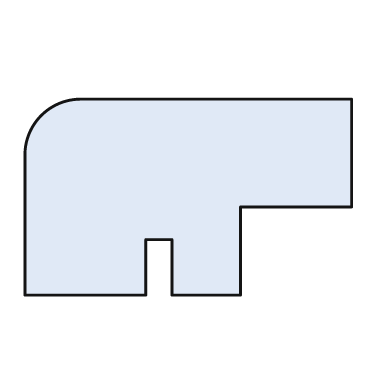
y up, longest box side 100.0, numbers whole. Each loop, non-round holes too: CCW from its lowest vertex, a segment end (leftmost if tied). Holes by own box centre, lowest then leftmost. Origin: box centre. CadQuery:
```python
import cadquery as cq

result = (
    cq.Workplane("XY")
    .moveTo(-50.0, -30.0)
    .lineTo(-13.0, -30.0)
    .lineTo(-13.0, -13.0)
    .lineTo(-5.0, -13.0)
    .lineTo(-5.0, -30.0)
    .lineTo(16.0, -30.0)
    .lineTo(16.0, -3.0)
    .lineTo(50.0, -3.0)
    .lineTo(50.0, 30.0)
    .lineTo(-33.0, 30.0)
    .threePointArc((-45.0, 25.0), (-50.0, 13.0))
    .close()
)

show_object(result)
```